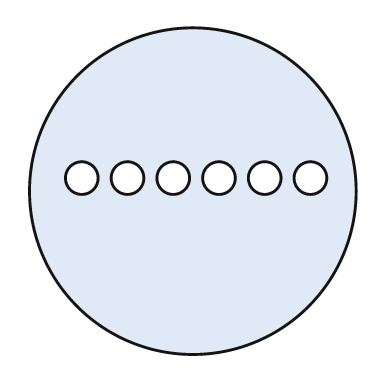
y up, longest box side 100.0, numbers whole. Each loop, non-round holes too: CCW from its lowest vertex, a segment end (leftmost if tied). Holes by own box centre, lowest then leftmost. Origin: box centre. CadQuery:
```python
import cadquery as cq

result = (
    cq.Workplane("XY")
    .moveTo(0.0, 0.0)
    .circle(50.0)
    .moveTo(-34.0, 4.0)
    .circle(5.0)
    .moveTo(-20.0, 4.0)
    .circle(5.0)
    .moveTo(-6.0, 4.0)
    .circle(5.0)
    .moveTo(8.0, 4.0)
    .circle(5.0)
    .moveTo(22.0, 4.0)
    .circle(5.0)
    .moveTo(36.0, 4.0)
    .circle(5.0)
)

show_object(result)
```